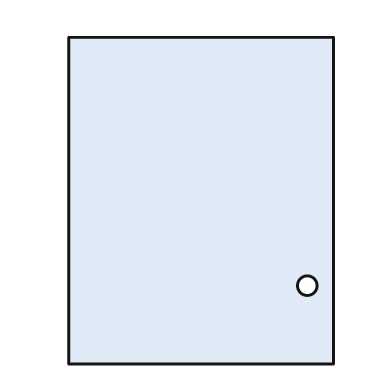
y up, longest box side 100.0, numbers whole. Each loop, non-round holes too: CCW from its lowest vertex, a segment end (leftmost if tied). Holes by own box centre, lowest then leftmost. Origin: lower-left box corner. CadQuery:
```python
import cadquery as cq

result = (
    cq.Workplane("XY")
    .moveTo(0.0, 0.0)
    .lineTo(81.0, 0.0)
    .lineTo(81.0, 100.0)
    .lineTo(0.0, 100.0)
    .close()
    .moveTo(73.0, 24.0)
    .circle(3.0)
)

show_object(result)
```